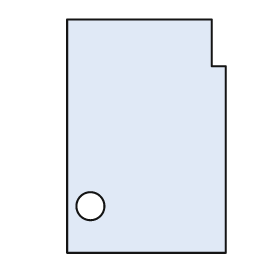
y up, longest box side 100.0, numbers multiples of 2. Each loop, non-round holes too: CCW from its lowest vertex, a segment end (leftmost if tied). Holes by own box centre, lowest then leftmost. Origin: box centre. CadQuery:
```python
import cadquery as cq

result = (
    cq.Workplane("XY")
    .moveTo(-34.0, -50.0)
    .lineTo(34.0, -50.0)
    .lineTo(34.0, 30.0)
    .lineTo(28.0, 30.0)
    .lineTo(28.0, 50.0)
    .lineTo(-34.0, 50.0)
    .close()
    .moveTo(-24.0, -30.0)
    .circle(6.0)
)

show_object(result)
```